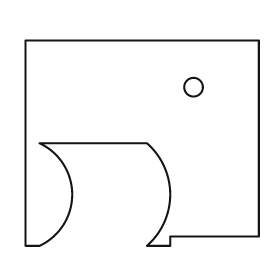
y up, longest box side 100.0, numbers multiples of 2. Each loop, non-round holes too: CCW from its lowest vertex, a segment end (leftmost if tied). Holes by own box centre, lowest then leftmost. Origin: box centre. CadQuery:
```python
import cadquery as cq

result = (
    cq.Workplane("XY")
    .moveTo(-50.0, -44.0)
    .lineTo(-44.0, -44.0)
    .threePointArc((-30.0, -22.0), (-44.0, 0.0))
    .lineTo(2.0, 0.0)
    .threePointArc((12.0, -22.0), (2.0, -44.0))
    .lineTo(12.0, -44.0)
    .lineTo(12.0, -40.0)
    .lineTo(50.0, -40.0)
    .lineTo(50.0, 44.0)
    .lineTo(-50.0, 44.0)
    .close()
    .moveTo(22.0, 24.0)
    .circle(4.0)
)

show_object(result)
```